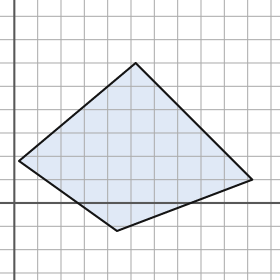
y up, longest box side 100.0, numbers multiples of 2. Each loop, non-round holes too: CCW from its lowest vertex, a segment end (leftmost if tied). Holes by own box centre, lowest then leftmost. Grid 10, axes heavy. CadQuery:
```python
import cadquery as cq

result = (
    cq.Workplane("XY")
    .moveTo(44.0, -12.0)
    .lineTo(102.0, 10.0)
    .lineTo(52.0, 60.0)
    .lineTo(2.0, 18.0)
    .close()
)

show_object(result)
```